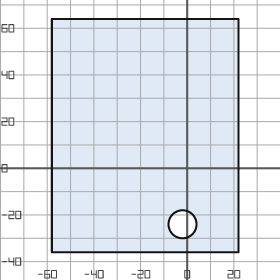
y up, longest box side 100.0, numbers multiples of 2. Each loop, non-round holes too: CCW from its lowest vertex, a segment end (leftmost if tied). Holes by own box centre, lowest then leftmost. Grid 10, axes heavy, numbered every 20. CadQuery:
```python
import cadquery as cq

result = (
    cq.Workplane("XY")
    .moveTo(-58.0, -36.0)
    .lineTo(22.0, -36.0)
    .lineTo(22.0, 64.0)
    .lineTo(-58.0, 64.0)
    .close()
    .moveTo(-2.0, -24.0)
    .circle(6.0)
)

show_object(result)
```